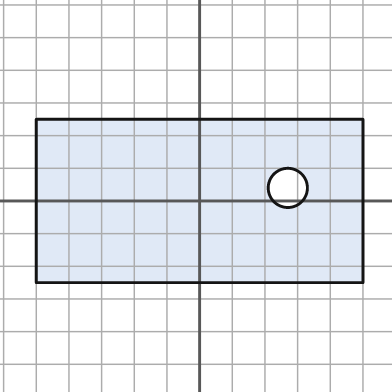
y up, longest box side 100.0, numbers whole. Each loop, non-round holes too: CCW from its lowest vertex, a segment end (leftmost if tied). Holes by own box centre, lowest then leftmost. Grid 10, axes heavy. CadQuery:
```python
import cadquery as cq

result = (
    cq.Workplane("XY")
    .moveTo(-50.0, -25.0)
    .lineTo(50.0, -25.0)
    .lineTo(50.0, 25.0)
    .lineTo(-50.0, 25.0)
    .close()
    .moveTo(27.0, 4.0)
    .circle(6.0)
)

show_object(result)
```